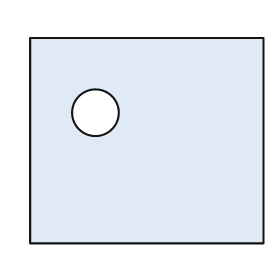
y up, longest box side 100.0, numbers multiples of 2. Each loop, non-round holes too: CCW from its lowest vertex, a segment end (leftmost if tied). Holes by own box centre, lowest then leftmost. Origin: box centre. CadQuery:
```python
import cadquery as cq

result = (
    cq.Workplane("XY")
    .moveTo(-50.0, -44.0)
    .lineTo(50.0, -44.0)
    .lineTo(50.0, 44.0)
    .lineTo(-50.0, 44.0)
    .close()
    .moveTo(-22.0, 12.0)
    .circle(10.0)
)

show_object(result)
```